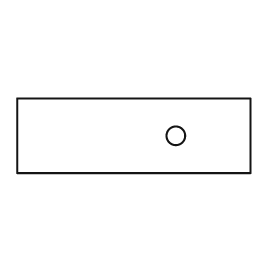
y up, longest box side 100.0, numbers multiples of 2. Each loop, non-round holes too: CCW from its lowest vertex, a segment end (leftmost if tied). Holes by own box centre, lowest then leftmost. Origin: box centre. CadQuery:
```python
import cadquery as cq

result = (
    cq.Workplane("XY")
    .moveTo(-50.0, -16.0)
    .lineTo(50.0, -16.0)
    .lineTo(50.0, 16.0)
    .lineTo(-50.0, 16.0)
    .close()
    .moveTo(18.0, 0.0)
    .circle(4.0)
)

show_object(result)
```